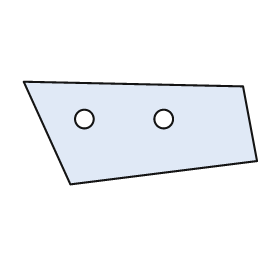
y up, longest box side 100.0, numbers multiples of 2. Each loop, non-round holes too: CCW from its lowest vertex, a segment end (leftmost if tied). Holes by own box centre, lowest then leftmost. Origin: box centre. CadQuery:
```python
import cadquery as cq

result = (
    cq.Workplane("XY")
    .moveTo(-30.0, -22.0)
    .lineTo(50.0, -12.0)
    .lineTo(44.0, 20.0)
    .lineTo(-50.0, 22.0)
    .close()
    .moveTo(-24.0, 6.0)
    .circle(4.0)
    .moveTo(10.0, 6.0)
    .circle(4.0)
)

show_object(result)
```